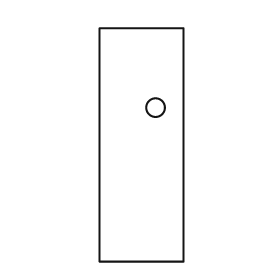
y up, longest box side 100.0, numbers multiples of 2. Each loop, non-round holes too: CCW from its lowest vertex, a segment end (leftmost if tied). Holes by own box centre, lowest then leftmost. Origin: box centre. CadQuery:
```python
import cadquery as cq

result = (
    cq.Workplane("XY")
    .moveTo(-18.0, -50.0)
    .lineTo(18.0, -50.0)
    .lineTo(18.0, 50.0)
    .lineTo(-18.0, 50.0)
    .close()
    .moveTo(6.0, 16.0)
    .circle(4.0)
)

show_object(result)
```